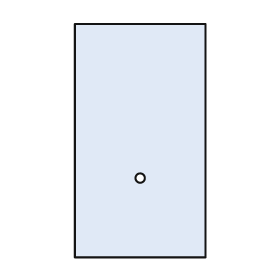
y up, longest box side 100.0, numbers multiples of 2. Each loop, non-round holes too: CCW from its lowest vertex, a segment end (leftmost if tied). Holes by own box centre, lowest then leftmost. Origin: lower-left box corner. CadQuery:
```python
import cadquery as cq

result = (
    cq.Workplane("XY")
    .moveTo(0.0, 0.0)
    .lineTo(56.0, 0.0)
    .lineTo(56.0, 100.0)
    .lineTo(0.0, 100.0)
    .close()
    .moveTo(28.0, 34.0)
    .circle(2.0)
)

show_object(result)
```